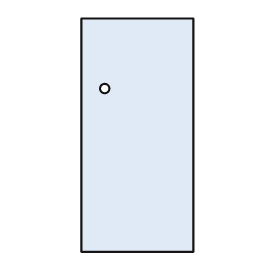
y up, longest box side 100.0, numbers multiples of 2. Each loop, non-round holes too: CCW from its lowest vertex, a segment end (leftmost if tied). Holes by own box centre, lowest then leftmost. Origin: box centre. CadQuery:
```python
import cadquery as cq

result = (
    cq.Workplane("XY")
    .moveTo(-24.0, -50.0)
    .lineTo(24.0, -50.0)
    .lineTo(24.0, 50.0)
    .lineTo(-24.0, 50.0)
    .close()
    .moveTo(-14.0, 20.0)
    .circle(2.0)
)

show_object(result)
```